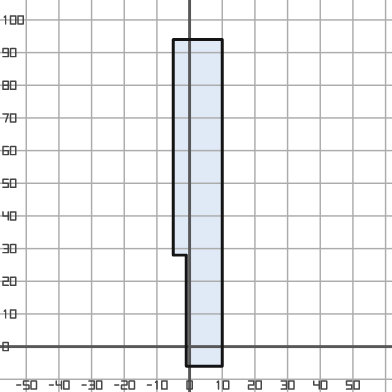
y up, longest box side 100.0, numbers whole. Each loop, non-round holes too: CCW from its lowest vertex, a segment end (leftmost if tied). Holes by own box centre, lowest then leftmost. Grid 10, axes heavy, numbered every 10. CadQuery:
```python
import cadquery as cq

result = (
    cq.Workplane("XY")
    .moveTo(-1.0, -6.0)
    .lineTo(10.0, -6.0)
    .lineTo(10.0, 94.0)
    .lineTo(-5.0, 94.0)
    .lineTo(-5.0, 28.0)
    .lineTo(-1.0, 28.0)
    .close()
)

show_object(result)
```